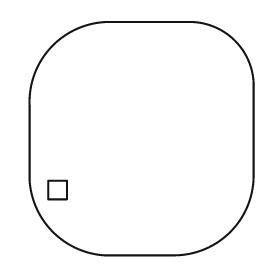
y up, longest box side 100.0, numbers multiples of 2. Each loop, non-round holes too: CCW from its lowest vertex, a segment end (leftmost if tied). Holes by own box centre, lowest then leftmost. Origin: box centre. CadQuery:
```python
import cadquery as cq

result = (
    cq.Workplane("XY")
    .moveTo(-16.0, -50.0)
    .lineTo(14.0, -50.0)
    .threePointArc((38.0, -40.0), (48.0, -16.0))
    .lineTo(48.0, 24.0)
    .threePointArc((40.0, 42.0), (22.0, 50.0))
    .lineTo(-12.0, 50.0)
    .threePointArc((-38.0, 40.0), (-48.0, 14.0))
    .lineTo(-48.0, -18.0)
    .threePointArc((-38.0, -40.0), (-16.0, -50.0))
    .close()
    .moveTo(-40.0, -26.0)
    .lineTo(-32.0, -26.0)
    .lineTo(-32.0, -18.0)
    .lineTo(-40.0, -18.0)
    .close()
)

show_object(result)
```